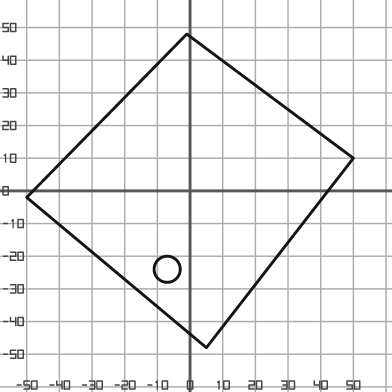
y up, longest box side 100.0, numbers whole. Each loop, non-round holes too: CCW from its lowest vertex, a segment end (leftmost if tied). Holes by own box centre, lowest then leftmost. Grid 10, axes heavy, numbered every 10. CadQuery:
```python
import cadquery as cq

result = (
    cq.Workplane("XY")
    .moveTo(5.0, -48.0)
    .lineTo(50.0, 10.0)
    .lineTo(-1.0, 48.0)
    .lineTo(-50.0, -2.0)
    .close()
    .moveTo(-7.0, -24.0)
    .circle(4.0)
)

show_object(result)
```